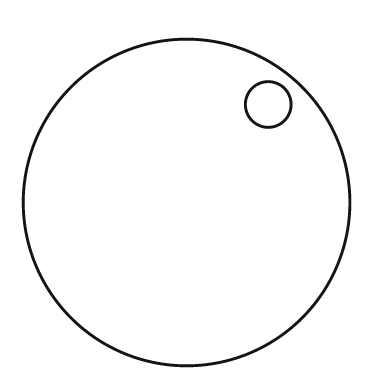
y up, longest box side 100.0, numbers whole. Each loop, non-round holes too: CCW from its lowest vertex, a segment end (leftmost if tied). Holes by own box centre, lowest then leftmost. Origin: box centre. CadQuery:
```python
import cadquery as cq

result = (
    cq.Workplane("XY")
    .moveTo(0.0, 0.0)
    .circle(50.0)
    .moveTo(25.0, 30.0)
    .circle(7.0)
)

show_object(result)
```